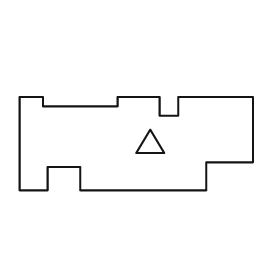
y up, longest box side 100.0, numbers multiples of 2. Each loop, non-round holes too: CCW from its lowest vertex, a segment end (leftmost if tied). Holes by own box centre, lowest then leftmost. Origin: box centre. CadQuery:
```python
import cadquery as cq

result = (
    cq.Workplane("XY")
    .moveTo(-50.0, -20.0)
    .lineTo(-38.0, -20.0)
    .lineTo(-38.0, -10.0)
    .lineTo(-24.0, -10.0)
    .lineTo(-24.0, -20.0)
    .lineTo(30.0, -20.0)
    .lineTo(30.0, -8.0)
    .lineTo(50.0, -8.0)
    .lineTo(50.0, 20.0)
    .lineTo(18.0, 20.0)
    .lineTo(18.0, 12.0)
    .lineTo(10.0, 12.0)
    .lineTo(10.0, 20.0)
    .lineTo(-8.0, 20.0)
    .lineTo(-8.0, 16.0)
    .lineTo(-40.0, 16.0)
    .lineTo(-40.0, 20.0)
    .lineTo(-50.0, 20.0)
    .close()
    .moveTo(0.0, -4.0)
    .lineTo(12.0, -4.0)
    .lineTo(6.0, 6.0)
    .close()
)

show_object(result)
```